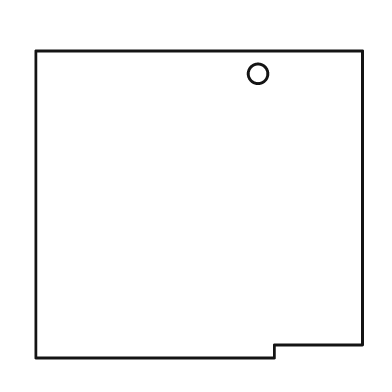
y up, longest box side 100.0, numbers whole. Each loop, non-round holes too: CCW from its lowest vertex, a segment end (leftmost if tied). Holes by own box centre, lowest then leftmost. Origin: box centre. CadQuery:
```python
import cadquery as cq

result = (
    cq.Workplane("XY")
    .moveTo(-50.0, -47.0)
    .lineTo(23.0, -47.0)
    .lineTo(23.0, -43.0)
    .lineTo(50.0, -43.0)
    .lineTo(50.0, 47.0)
    .lineTo(-50.0, 47.0)
    .close()
    .moveTo(18.0, 40.0)
    .circle(3.0)
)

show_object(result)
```